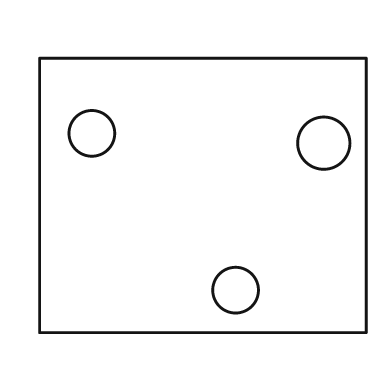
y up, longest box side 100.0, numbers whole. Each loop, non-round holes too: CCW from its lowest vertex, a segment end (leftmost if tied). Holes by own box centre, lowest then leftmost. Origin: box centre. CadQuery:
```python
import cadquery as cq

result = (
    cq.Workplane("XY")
    .moveTo(-50.0, -42.0)
    .lineTo(50.0, -42.0)
    .lineTo(50.0, 42.0)
    .lineTo(-50.0, 42.0)
    .close()
    .moveTo(10.0, -29.0)
    .circle(7.0)
    .moveTo(37.0, 16.0)
    .circle(8.0)
    .moveTo(-34.0, 19.0)
    .circle(7.0)
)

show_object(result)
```